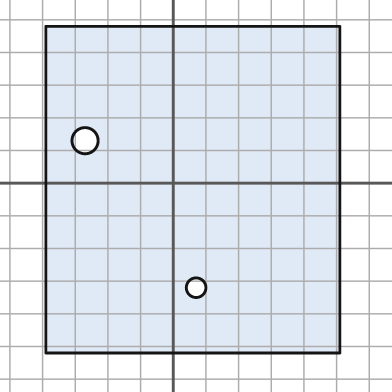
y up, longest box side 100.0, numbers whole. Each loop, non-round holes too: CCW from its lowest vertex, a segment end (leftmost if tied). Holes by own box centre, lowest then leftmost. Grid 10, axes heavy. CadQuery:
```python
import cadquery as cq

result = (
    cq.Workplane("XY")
    .moveTo(-39.0, -52.0)
    .lineTo(51.0, -52.0)
    .lineTo(51.0, 48.0)
    .lineTo(-39.0, 48.0)
    .close()
    .moveTo(7.0, -32.0)
    .circle(3.0)
    .moveTo(-27.0, 13.0)
    .circle(4.0)
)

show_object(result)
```